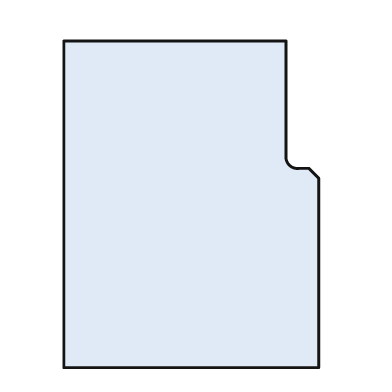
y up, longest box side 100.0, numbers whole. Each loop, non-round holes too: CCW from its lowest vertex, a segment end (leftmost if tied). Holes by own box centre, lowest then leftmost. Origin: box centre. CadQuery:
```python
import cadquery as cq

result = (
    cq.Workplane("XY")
    .moveTo(-39.0, -50.0)
    .lineTo(39.0, -50.0)
    .lineTo(39.0, 8.0)
    .lineTo(36.0, 11.0)
    .lineTo(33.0, 11.0)
    .threePointArc((30.0, 12.0), (29.0, 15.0))
    .lineTo(29.0, 50.0)
    .lineTo(-39.0, 50.0)
    .close()
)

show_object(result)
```